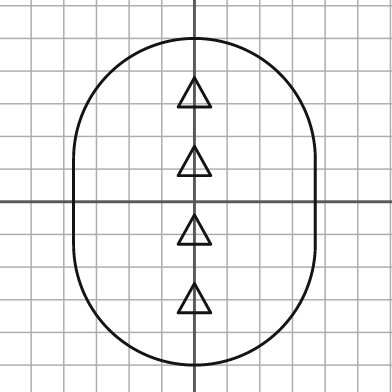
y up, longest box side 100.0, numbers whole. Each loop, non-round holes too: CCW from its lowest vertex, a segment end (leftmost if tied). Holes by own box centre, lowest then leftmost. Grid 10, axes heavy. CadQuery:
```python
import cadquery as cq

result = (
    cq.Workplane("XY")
    .moveTo(-37.0, -13.0)
    .threePointArc((0.0, -50.0), (37.0, -13.0))
    .lineTo(37.0, 13.0)
    .threePointArc((0.0, 50.0), (-37.0, 13.0))
    .close()
    .moveTo(-5.0, -34.0)
    .lineTo(5.0, -34.0)
    .lineTo(0.0, -25.0)
    .close()
    .moveTo(-5.0, -13.0)
    .lineTo(5.0, -13.0)
    .lineTo(0.0, -4.0)
    .close()
    .moveTo(-5.0, 8.0)
    .lineTo(5.0, 8.0)
    .lineTo(0.0, 17.0)
    .close()
    .moveTo(-5.0, 29.0)
    .lineTo(5.0, 29.0)
    .lineTo(0.0, 38.0)
    .close()
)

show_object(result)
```